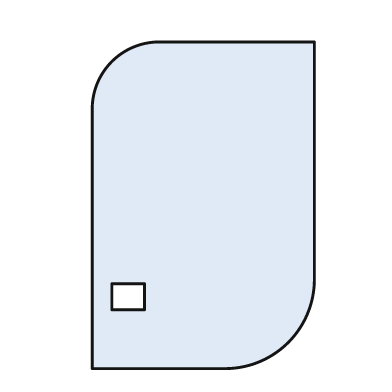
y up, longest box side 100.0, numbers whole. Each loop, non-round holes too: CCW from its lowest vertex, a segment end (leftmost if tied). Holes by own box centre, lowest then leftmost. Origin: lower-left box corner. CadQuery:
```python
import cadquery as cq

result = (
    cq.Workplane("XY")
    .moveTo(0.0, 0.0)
    .lineTo(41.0, 0.0)
    .threePointArc((60.0, 8.0), (68.0, 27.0))
    .lineTo(68.0, 100.0)
    .lineTo(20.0, 100.0)
    .threePointArc((6.0, 94.0), (0.0, 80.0))
    .close()
    .moveTo(6.0, 18.0)
    .lineTo(16.0, 18.0)
    .lineTo(16.0, 26.0)
    .lineTo(6.0, 26.0)
    .close()
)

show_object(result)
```